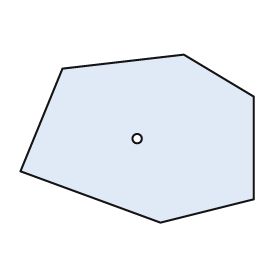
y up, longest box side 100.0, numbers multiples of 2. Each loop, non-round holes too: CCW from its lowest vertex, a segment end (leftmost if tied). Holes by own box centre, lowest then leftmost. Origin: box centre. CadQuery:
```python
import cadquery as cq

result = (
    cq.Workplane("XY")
    .moveTo(10.0, -36.0)
    .lineTo(50.0, -26.0)
    .lineTo(50.0, 18.0)
    .lineTo(20.0, 36.0)
    .lineTo(-32.0, 30.0)
    .lineTo(-50.0, -14.0)
    .close()
    .moveTo(0.0, 0.0)
    .circle(2.0)
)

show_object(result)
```